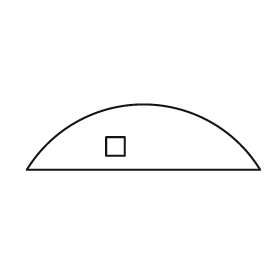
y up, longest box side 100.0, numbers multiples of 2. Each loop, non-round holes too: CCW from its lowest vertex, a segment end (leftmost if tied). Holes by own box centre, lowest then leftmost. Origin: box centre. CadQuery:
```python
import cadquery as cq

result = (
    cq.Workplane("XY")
    .moveTo(-50.0, -14.0)
    .lineTo(50.0, -14.0)
    .threePointArc((0.0, 14.0), (-50.0, -14.0))
    .close()
    .moveTo(-16.0, -8.0)
    .lineTo(-8.0, -8.0)
    .lineTo(-8.0, 0.0)
    .lineTo(-16.0, 0.0)
    .close()
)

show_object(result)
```